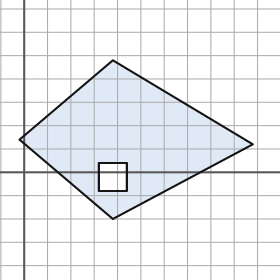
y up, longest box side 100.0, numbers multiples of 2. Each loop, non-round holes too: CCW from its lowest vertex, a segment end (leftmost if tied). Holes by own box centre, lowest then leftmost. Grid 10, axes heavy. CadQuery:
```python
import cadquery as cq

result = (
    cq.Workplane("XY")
    .moveTo(38.0, -20.0)
    .lineTo(98.0, 12.0)
    .lineTo(38.0, 48.0)
    .lineTo(-2.0, 14.0)
    .close()
    .moveTo(32.0, -8.0)
    .lineTo(44.0, -8.0)
    .lineTo(44.0, 4.0)
    .lineTo(32.0, 4.0)
    .close()
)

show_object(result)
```